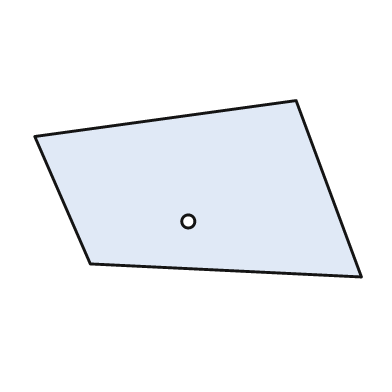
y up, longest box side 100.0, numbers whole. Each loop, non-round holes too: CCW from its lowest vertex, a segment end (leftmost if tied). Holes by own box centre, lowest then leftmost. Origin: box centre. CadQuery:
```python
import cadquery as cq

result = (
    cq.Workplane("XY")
    .moveTo(50.0, -27.0)
    .lineTo(30.0, 27.0)
    .lineTo(-50.0, 16.0)
    .lineTo(-33.0, -23.0)
    .close()
    .moveTo(-3.0, -10.0)
    .circle(2.0)
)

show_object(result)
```